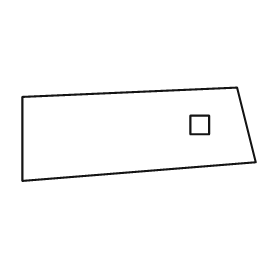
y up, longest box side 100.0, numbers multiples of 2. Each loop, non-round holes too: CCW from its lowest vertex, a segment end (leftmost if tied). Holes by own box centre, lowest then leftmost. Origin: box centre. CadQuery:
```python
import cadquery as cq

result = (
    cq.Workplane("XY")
    .moveTo(-50.0, -20.0)
    .lineTo(50.0, -12.0)
    .lineTo(42.0, 20.0)
    .lineTo(-50.0, 16.0)
    .close()
    .moveTo(22.0, 0.0)
    .lineTo(30.0, 0.0)
    .lineTo(30.0, 8.0)
    .lineTo(22.0, 8.0)
    .close()
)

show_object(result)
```